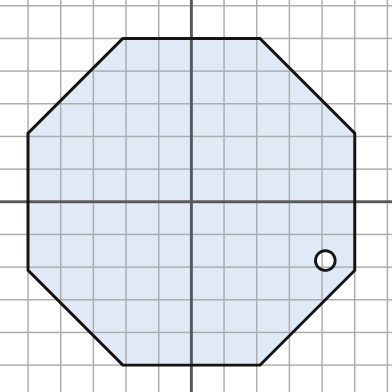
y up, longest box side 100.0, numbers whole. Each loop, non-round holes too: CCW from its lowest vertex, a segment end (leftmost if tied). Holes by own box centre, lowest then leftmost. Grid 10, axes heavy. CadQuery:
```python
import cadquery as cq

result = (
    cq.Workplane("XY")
    .moveTo(-21.0, -50.0)
    .lineTo(21.0, -50.0)
    .lineTo(50.0, -21.0)
    .lineTo(50.0, 21.0)
    .lineTo(21.0, 50.0)
    .lineTo(-21.0, 50.0)
    .lineTo(-50.0, 21.0)
    .lineTo(-50.0, -21.0)
    .close()
    .moveTo(41.0, -18.0)
    .circle(3.0)
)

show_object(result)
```